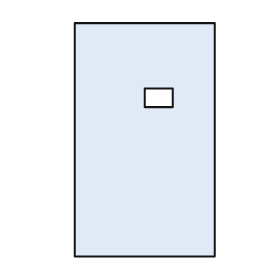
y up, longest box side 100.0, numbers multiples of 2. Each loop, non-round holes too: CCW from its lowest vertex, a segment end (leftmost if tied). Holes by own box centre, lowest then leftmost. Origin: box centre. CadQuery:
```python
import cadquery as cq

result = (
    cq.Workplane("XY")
    .moveTo(-30.0, -50.0)
    .lineTo(30.0, -50.0)
    .lineTo(30.0, 50.0)
    .lineTo(-30.0, 50.0)
    .close()
    .moveTo(0.0, 14.0)
    .lineTo(12.0, 14.0)
    .lineTo(12.0, 22.0)
    .lineTo(0.0, 22.0)
    .close()
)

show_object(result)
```